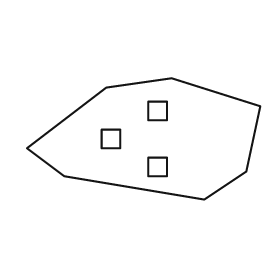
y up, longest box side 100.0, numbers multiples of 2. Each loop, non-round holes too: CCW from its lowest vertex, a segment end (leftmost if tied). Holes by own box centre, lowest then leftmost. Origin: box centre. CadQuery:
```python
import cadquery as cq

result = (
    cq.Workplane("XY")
    .moveTo(26.0, -26.0)
    .lineTo(44.0, -14.0)
    .lineTo(50.0, 14.0)
    .lineTo(12.0, 26.0)
    .lineTo(-16.0, 22.0)
    .lineTo(-50.0, -4.0)
    .lineTo(-34.0, -16.0)
    .close()
    .moveTo(2.0, -16.0)
    .lineTo(10.0, -16.0)
    .lineTo(10.0, -8.0)
    .lineTo(2.0, -8.0)
    .close()
    .moveTo(-18.0, -4.0)
    .lineTo(-10.0, -4.0)
    .lineTo(-10.0, 4.0)
    .lineTo(-18.0, 4.0)
    .close()
    .moveTo(2.0, 8.0)
    .lineTo(10.0, 8.0)
    .lineTo(10.0, 16.0)
    .lineTo(2.0, 16.0)
    .close()
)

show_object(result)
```